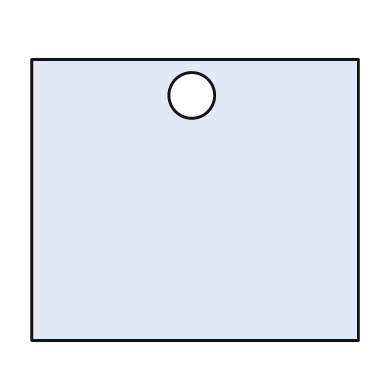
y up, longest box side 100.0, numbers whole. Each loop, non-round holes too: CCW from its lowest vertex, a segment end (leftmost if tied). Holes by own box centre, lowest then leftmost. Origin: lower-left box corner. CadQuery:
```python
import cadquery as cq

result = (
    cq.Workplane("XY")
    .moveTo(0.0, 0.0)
    .lineTo(100.0, 0.0)
    .lineTo(100.0, 86.0)
    .lineTo(0.0, 86.0)
    .close()
    .moveTo(49.0, 75.0)
    .circle(7.0)
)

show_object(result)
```